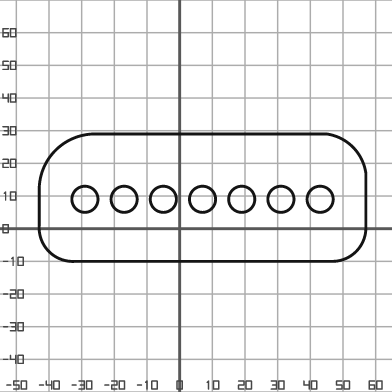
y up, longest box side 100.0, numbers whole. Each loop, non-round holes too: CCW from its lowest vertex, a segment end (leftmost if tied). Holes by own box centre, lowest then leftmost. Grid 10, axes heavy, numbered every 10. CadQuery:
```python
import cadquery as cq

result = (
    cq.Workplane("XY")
    .moveTo(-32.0, -10.0)
    .lineTo(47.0, -10.0)
    .threePointArc((54.0, -7.0), (57.0, 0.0))
    .lineTo(57.0, 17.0)
    .threePointArc((53.0, 25.0), (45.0, 29.0))
    .lineTo(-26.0, 29.0)
    .threePointArc((-38.0, 24.0), (-43.0, 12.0))
    .lineTo(-43.0, 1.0)
    .threePointArc((-40.0, -7.0), (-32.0, -10.0))
    .close()
    .moveTo(-29.0, 9.0)
    .circle(4.0)
    .moveTo(-17.0, 9.0)
    .circle(4.0)
    .moveTo(-5.0, 9.0)
    .circle(4.0)
    .moveTo(7.0, 9.0)
    .circle(4.0)
    .moveTo(19.0, 9.0)
    .circle(4.0)
    .moveTo(31.0, 9.0)
    .circle(4.0)
    .moveTo(43.0, 9.0)
    .circle(4.0)
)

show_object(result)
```